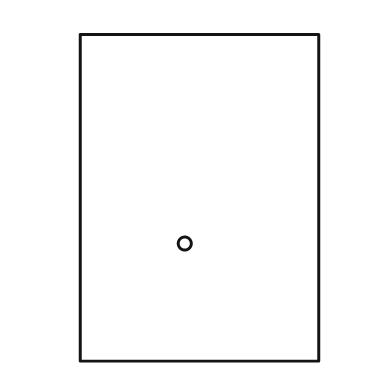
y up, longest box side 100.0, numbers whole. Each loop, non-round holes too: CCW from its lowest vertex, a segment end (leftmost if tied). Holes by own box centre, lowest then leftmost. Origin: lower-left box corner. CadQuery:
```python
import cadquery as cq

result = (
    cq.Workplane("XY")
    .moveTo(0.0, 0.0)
    .lineTo(73.0, 0.0)
    .lineTo(73.0, 100.0)
    .lineTo(0.0, 100.0)
    .close()
    .moveTo(32.0, 36.0)
    .circle(2.0)
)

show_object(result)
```